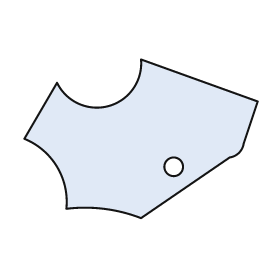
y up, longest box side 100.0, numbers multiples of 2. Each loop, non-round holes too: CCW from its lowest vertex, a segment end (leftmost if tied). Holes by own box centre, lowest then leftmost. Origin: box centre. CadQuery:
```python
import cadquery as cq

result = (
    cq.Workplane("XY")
    .moveTo(0.0, -34.0)
    .lineTo(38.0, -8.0)
    .threePointArc((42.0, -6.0), (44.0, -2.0))
    .lineTo(50.0, 16.0)
    .lineTo(0.0, 34.0)
    .threePointArc((-14.0, 14.0), (-36.0, 24.0))
    .lineTo(-50.0, 0.0)
    .threePointArc((-36.0, -12.0), (-32.0, -30.0))
    .threePointArc((-16.0, -30.0), (0.0, -34.0))
    .close()
    .moveTo(14.0, -12.0)
    .circle(4.0)
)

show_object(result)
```